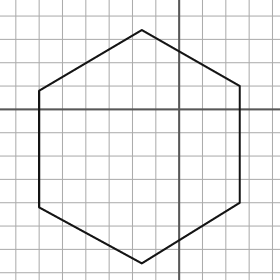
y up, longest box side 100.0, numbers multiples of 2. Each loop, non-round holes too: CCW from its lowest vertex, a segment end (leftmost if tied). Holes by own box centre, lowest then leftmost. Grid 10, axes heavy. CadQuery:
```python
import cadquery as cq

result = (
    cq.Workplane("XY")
    .moveTo(-16.0, -66.0)
    .lineTo(26.0, -40.0)
    .lineTo(26.0, 10.0)
    .lineTo(-16.0, 34.0)
    .lineTo(-60.0, 8.0)
    .lineTo(-60.0, -42.0)
    .close()
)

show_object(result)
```